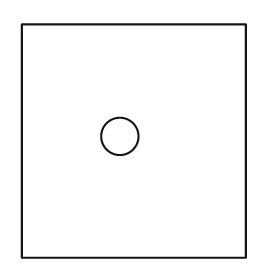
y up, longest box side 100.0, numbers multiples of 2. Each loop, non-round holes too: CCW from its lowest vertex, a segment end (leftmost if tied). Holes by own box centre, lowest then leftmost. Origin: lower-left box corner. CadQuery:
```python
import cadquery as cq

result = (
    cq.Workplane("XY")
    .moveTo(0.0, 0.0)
    .lineTo(96.0, 0.0)
    .lineTo(96.0, 100.0)
    .lineTo(0.0, 100.0)
    .close()
    .moveTo(42.0, 52.0)
    .circle(8.0)
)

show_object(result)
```